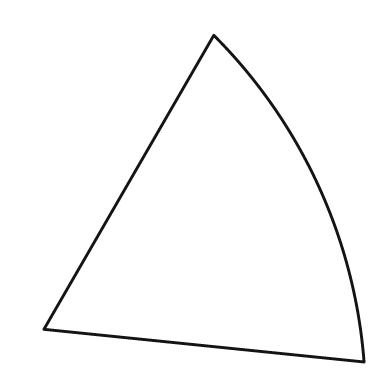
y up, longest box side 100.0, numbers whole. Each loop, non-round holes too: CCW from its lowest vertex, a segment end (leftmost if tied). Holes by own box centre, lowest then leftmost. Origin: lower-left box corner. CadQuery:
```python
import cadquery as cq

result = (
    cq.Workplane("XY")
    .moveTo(98.0, 0.0)
    .threePointArc((84.0, 54.0), (52.0, 100.0))
    .lineTo(0.0, 10.0)
    .close()
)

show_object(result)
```